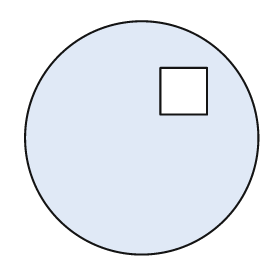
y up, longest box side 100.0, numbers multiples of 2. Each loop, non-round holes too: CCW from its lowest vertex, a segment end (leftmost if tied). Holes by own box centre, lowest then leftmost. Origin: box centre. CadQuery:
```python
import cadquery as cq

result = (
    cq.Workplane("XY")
    .moveTo(0.0, 0.0)
    .circle(50.0)
    .moveTo(8.0, 10.0)
    .lineTo(28.0, 10.0)
    .lineTo(28.0, 30.0)
    .lineTo(8.0, 30.0)
    .close()
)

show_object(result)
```